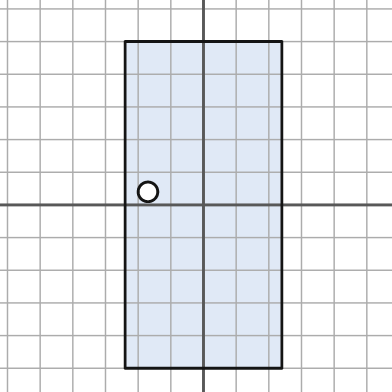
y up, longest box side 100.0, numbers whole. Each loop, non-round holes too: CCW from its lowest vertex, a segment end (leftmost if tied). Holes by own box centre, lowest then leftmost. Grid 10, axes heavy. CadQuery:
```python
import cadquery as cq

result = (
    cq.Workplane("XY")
    .moveTo(-24.0, -50.0)
    .lineTo(24.0, -50.0)
    .lineTo(24.0, 50.0)
    .lineTo(-24.0, 50.0)
    .close()
    .moveTo(-17.0, 4.0)
    .circle(3.0)
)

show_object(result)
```